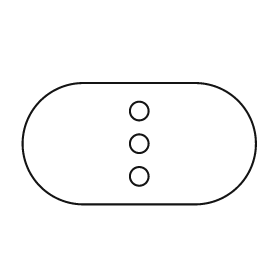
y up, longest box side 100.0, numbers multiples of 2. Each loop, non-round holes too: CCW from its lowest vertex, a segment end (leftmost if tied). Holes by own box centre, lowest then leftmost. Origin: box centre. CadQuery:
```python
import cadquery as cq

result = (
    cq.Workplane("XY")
    .moveTo(-24.0, -26.0)
    .lineTo(24.0, -26.0)
    .threePointArc((50.0, 0.0), (24.0, 26.0))
    .lineTo(-24.0, 26.0)
    .threePointArc((-50.0, 0.0), (-24.0, -26.0))
    .close()
    .moveTo(0.0, -14.0)
    .circle(4.0)
    .moveTo(0.0, 0.0)
    .circle(4.0)
    .moveTo(0.0, 14.0)
    .circle(4.0)
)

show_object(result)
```